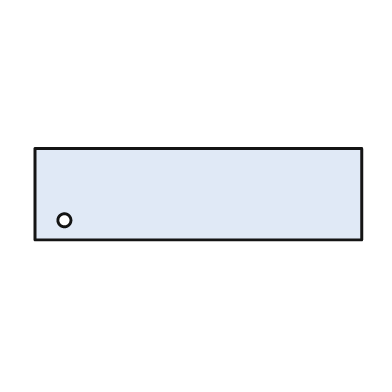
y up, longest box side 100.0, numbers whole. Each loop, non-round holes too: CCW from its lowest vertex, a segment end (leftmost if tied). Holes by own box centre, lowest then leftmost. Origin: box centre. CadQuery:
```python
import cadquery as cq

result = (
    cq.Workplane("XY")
    .moveTo(-50.0, -14.0)
    .lineTo(50.0, -14.0)
    .lineTo(50.0, 14.0)
    .lineTo(-50.0, 14.0)
    .close()
    .moveTo(-41.0, -8.0)
    .circle(2.0)
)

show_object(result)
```